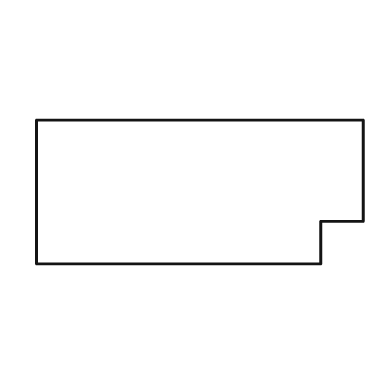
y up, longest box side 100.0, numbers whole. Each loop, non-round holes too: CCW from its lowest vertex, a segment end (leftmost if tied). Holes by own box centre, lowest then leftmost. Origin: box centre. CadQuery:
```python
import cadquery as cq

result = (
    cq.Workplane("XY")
    .moveTo(-50.0, -22.0)
    .lineTo(37.0, -22.0)
    .lineTo(37.0, -9.0)
    .lineTo(50.0, -9.0)
    .lineTo(50.0, 22.0)
    .lineTo(-50.0, 22.0)
    .close()
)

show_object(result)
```